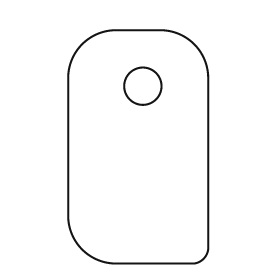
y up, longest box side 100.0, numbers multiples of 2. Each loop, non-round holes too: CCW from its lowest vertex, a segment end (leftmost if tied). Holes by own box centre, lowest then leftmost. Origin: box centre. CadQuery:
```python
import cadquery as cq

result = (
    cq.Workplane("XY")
    .moveTo(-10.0, -50.0)
    .lineTo(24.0, -50.0)
    .threePointArc((28.0, -48.0), (30.0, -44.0))
    .lineTo(30.0, 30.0)
    .threePointArc((24.0, 44.0), (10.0, 50.0))
    .lineTo(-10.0, 50.0)
    .threePointArc((-24.0, 44.0), (-30.0, 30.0))
    .lineTo(-30.0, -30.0)
    .threePointArc((-24.0, -44.0), (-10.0, -50.0))
    .close()
    .moveTo(2.0, 26.0)
    .circle(8.0)
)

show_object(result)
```